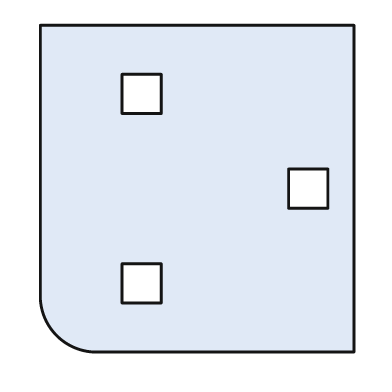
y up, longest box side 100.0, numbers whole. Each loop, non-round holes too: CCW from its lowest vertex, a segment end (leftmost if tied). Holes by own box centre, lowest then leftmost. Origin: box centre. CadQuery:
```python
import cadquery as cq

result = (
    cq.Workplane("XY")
    .moveTo(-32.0, -50.0)
    .lineTo(48.0, -50.0)
    .lineTo(48.0, 50.0)
    .lineTo(-48.0, 50.0)
    .lineTo(-48.0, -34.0)
    .threePointArc((-43.0, -45.0), (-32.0, -50.0))
    .close()
    .moveTo(-23.0, -35.0)
    .lineTo(-11.0, -35.0)
    .lineTo(-11.0, -23.0)
    .lineTo(-23.0, -23.0)
    .close()
    .moveTo(28.0, -6.0)
    .lineTo(40.0, -6.0)
    .lineTo(40.0, 6.0)
    .lineTo(28.0, 6.0)
    .close()
    .moveTo(-23.0, 23.0)
    .lineTo(-11.0, 23.0)
    .lineTo(-11.0, 35.0)
    .lineTo(-23.0, 35.0)
    .close()
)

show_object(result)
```